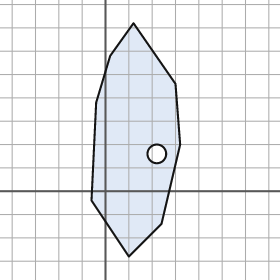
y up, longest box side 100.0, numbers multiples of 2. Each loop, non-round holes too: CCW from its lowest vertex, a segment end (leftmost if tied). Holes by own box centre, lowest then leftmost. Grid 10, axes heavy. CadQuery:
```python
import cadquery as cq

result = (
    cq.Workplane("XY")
    .moveTo(10.0, -28.0)
    .lineTo(24.0, -14.0)
    .lineTo(32.0, 20.0)
    .lineTo(30.0, 46.0)
    .lineTo(12.0, 72.0)
    .lineTo(2.0, 58.0)
    .lineTo(-4.0, 38.0)
    .lineTo(-6.0, -4.0)
    .close()
    .moveTo(22.0, 16.0)
    .circle(4.0)
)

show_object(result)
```